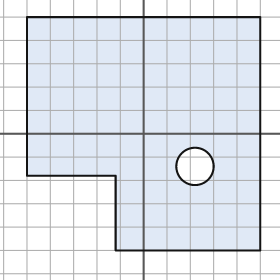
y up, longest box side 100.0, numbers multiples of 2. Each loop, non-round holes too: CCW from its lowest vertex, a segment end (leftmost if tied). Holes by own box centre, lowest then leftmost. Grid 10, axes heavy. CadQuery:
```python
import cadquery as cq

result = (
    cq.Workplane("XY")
    .moveTo(-12.0, -50.0)
    .lineTo(50.0, -50.0)
    .lineTo(50.0, 50.0)
    .lineTo(-50.0, 50.0)
    .lineTo(-50.0, -18.0)
    .lineTo(-12.0, -18.0)
    .close()
    .moveTo(22.0, -14.0)
    .circle(8.0)
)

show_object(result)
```